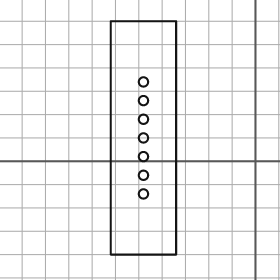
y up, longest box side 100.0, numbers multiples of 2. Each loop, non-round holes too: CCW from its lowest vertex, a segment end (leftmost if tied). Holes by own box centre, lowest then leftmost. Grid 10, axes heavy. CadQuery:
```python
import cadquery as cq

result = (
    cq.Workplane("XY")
    .moveTo(-62.0, -40.0)
    .lineTo(-34.0, -40.0)
    .lineTo(-34.0, 60.0)
    .lineTo(-62.0, 60.0)
    .close()
    .moveTo(-48.0, -14.0)
    .circle(2.0)
    .moveTo(-48.0, -6.0)
    .circle(2.0)
    .moveTo(-48.0, 2.0)
    .circle(2.0)
    .moveTo(-48.0, 10.0)
    .circle(2.0)
    .moveTo(-48.0, 18.0)
    .circle(2.0)
    .moveTo(-48.0, 26.0)
    .circle(2.0)
    .moveTo(-48.0, 34.0)
    .circle(2.0)
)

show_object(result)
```